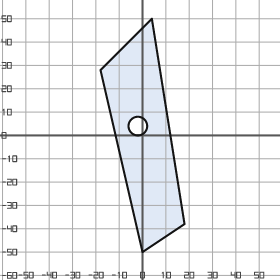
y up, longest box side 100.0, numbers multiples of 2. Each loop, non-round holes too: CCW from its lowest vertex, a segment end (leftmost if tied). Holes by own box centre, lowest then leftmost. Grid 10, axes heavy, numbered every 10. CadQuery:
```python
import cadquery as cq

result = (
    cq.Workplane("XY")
    .moveTo(0.0, -50.0)
    .lineTo(18.0, -38.0)
    .lineTo(4.0, 50.0)
    .lineTo(-18.0, 28.0)
    .close()
    .moveTo(-2.0, 4.0)
    .circle(4.0)
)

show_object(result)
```